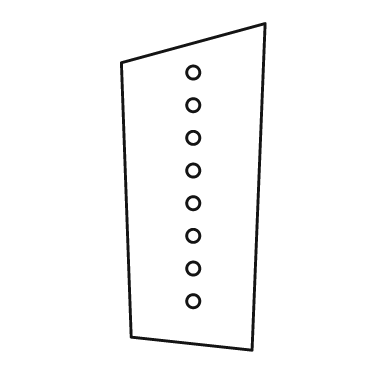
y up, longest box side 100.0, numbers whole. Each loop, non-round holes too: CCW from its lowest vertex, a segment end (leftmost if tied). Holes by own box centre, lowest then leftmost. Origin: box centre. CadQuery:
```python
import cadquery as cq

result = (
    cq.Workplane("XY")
    .moveTo(18.0, -50.0)
    .lineTo(22.0, 50.0)
    .lineTo(-22.0, 38.0)
    .lineTo(-19.0, -46.0)
    .close()
    .moveTo(0.0, -35.0)
    .circle(2.0)
    .moveTo(0.0, -25.0)
    .circle(2.0)
    .moveTo(0.0, -15.0)
    .circle(2.0)
    .moveTo(0.0, -5.0)
    .circle(2.0)
    .moveTo(0.0, 5.0)
    .circle(2.0)
    .moveTo(0.0, 15.0)
    .circle(2.0)
    .moveTo(0.0, 25.0)
    .circle(2.0)
    .moveTo(0.0, 35.0)
    .circle(2.0)
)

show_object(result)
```